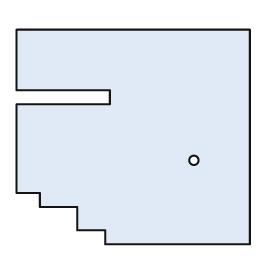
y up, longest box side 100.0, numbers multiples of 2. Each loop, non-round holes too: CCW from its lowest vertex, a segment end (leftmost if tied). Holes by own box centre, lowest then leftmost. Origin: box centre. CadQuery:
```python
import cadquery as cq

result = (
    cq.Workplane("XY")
    .moveTo(-12.0, -46.0)
    .lineTo(50.0, -46.0)
    .lineTo(50.0, 46.0)
    .lineTo(-50.0, 46.0)
    .lineTo(-50.0, 20.0)
    .lineTo(-10.0, 20.0)
    .lineTo(-10.0, 14.0)
    .lineTo(-50.0, 14.0)
    .lineTo(-50.0, -24.0)
    .lineTo(-40.0, -24.0)
    .lineTo(-40.0, -30.0)
    .lineTo(-24.0, -30.0)
    .lineTo(-24.0, -40.0)
    .lineTo(-12.0, -40.0)
    .close()
    .moveTo(26.0, -10.0)
    .circle(2.0)
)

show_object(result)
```